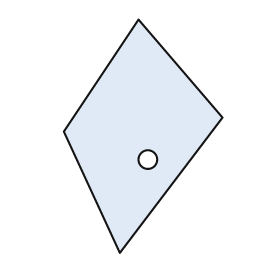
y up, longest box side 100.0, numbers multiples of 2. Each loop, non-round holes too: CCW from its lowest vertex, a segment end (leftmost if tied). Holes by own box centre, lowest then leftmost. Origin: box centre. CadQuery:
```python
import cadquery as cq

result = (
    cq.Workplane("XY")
    .moveTo(-10.0, -50.0)
    .lineTo(34.0, 8.0)
    .lineTo(-2.0, 50.0)
    .lineTo(-34.0, 2.0)
    .close()
    .moveTo(2.0, -10.0)
    .circle(4.0)
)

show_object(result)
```